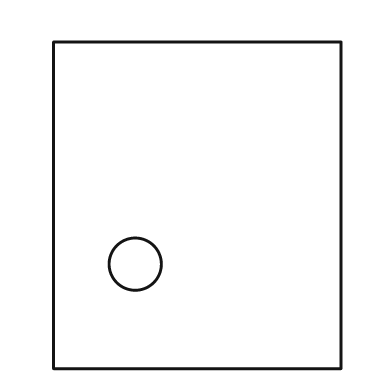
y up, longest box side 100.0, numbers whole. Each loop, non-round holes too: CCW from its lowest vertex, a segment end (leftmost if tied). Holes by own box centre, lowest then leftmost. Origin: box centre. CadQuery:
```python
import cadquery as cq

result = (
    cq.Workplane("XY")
    .moveTo(-44.0, -50.0)
    .lineTo(44.0, -50.0)
    .lineTo(44.0, 50.0)
    .lineTo(-44.0, 50.0)
    .close()
    .moveTo(-19.0, -18.0)
    .circle(8.0)
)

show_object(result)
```